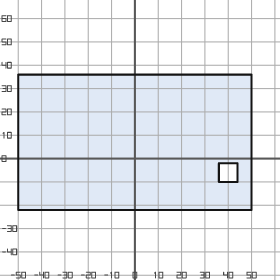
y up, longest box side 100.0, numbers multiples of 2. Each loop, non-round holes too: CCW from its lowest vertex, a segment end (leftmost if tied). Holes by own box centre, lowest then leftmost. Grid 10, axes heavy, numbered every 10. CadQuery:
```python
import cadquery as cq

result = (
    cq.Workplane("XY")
    .moveTo(-50.0, -22.0)
    .lineTo(50.0, -22.0)
    .lineTo(50.0, 36.0)
    .lineTo(-50.0, 36.0)
    .close()
    .moveTo(36.0, -10.0)
    .lineTo(44.0, -10.0)
    .lineTo(44.0, -2.0)
    .lineTo(36.0, -2.0)
    .close()
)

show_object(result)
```